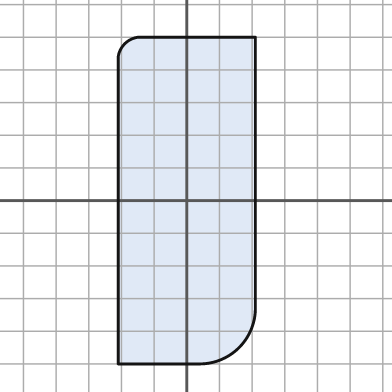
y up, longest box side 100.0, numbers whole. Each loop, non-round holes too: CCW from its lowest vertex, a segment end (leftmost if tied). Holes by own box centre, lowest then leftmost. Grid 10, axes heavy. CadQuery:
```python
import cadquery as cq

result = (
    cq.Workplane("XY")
    .moveTo(-21.0, -50.0)
    .lineTo(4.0, -50.0)
    .threePointArc((16.0, -45.0), (21.0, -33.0))
    .lineTo(21.0, 50.0)
    .lineTo(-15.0, 50.0)
    .threePointArc((-19.0, 48.0), (-21.0, 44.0))
    .close()
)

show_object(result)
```